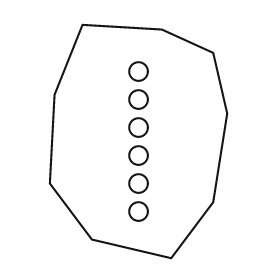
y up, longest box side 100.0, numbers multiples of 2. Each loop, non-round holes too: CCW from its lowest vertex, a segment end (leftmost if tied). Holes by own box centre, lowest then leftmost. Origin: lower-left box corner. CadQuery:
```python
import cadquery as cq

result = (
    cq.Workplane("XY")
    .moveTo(52.0, 0.0)
    .lineTo(70.0, 24.0)
    .lineTo(76.0, 62.0)
    .lineTo(70.0, 88.0)
    .lineTo(48.0, 98.0)
    .lineTo(14.0, 100.0)
    .lineTo(2.0, 70.0)
    .lineTo(0.0, 32.0)
    .lineTo(18.0, 8.0)
    .close()
    .moveTo(38.0, 20.0)
    .circle(4.0)
    .moveTo(38.0, 32.0)
    .circle(4.0)
    .moveTo(38.0, 44.0)
    .circle(4.0)
    .moveTo(38.0, 56.0)
    .circle(4.0)
    .moveTo(38.0, 68.0)
    .circle(4.0)
    .moveTo(38.0, 80.0)
    .circle(4.0)
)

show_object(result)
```